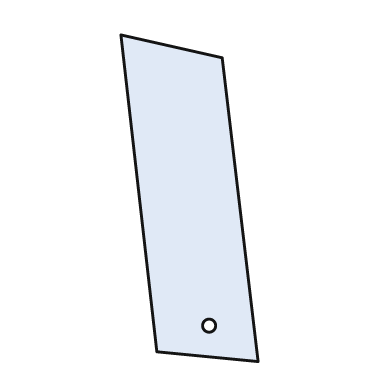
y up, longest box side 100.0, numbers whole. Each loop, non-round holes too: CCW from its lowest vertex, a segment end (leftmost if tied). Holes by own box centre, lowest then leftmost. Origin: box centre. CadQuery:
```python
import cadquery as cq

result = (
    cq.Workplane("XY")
    .moveTo(21.0, -50.0)
    .lineTo(10.0, 43.0)
    .lineTo(-21.0, 50.0)
    .lineTo(-10.0, -47.0)
    .close()
    .moveTo(6.0, -39.0)
    .circle(2.0)
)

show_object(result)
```